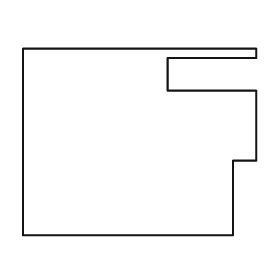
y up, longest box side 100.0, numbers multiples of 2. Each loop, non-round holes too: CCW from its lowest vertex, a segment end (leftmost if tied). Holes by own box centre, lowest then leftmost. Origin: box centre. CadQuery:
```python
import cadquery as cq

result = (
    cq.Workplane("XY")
    .moveTo(-50.0, -40.0)
    .lineTo(40.0, -40.0)
    .lineTo(40.0, -8.0)
    .lineTo(50.0, -8.0)
    .lineTo(50.0, 22.0)
    .lineTo(12.0, 22.0)
    .lineTo(12.0, 36.0)
    .lineTo(50.0, 36.0)
    .lineTo(50.0, 40.0)
    .lineTo(-50.0, 40.0)
    .close()
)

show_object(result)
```